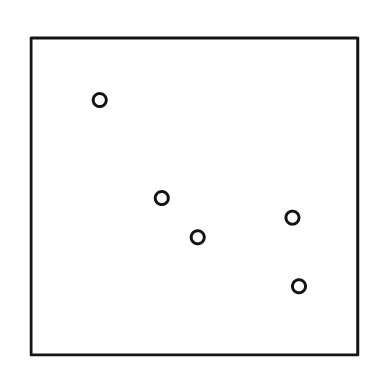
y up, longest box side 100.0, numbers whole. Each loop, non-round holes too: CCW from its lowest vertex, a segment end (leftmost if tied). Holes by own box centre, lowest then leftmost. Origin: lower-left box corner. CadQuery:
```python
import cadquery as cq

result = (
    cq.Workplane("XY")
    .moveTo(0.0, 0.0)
    .lineTo(100.0, 0.0)
    .lineTo(100.0, 97.0)
    .lineTo(0.0, 97.0)
    .close()
    .moveTo(82.0, 21.0)
    .circle(2.0)
    .moveTo(51.0, 36.0)
    .circle(2.0)
    .moveTo(80.0, 42.0)
    .circle(2.0)
    .moveTo(40.0, 48.0)
    .circle(2.0)
    .moveTo(21.0, 78.0)
    .circle(2.0)
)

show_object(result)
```